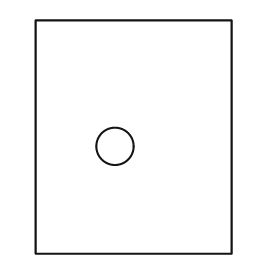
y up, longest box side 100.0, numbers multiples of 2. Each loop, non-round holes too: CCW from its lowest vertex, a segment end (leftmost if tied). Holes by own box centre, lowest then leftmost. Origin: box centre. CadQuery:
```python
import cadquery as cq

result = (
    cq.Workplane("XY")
    .moveTo(-42.0, -50.0)
    .lineTo(42.0, -50.0)
    .lineTo(42.0, 50.0)
    .lineTo(-42.0, 50.0)
    .close()
    .moveTo(-8.0, -4.0)
    .circle(8.0)
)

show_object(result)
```